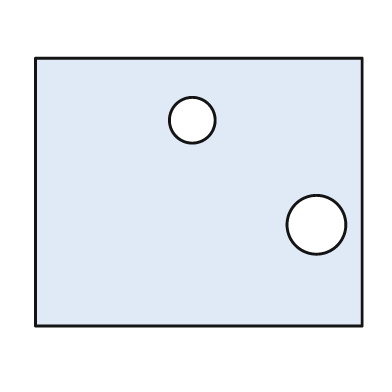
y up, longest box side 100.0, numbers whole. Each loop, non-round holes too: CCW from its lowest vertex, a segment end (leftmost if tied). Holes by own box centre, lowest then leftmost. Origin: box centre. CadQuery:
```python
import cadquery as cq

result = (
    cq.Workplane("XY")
    .moveTo(-50.0, -41.0)
    .lineTo(50.0, -41.0)
    .lineTo(50.0, 41.0)
    .lineTo(-50.0, 41.0)
    .close()
    .moveTo(36.0, -10.0)
    .circle(9.0)
    .moveTo(-2.0, 22.0)
    .circle(7.0)
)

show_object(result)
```